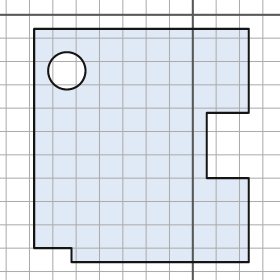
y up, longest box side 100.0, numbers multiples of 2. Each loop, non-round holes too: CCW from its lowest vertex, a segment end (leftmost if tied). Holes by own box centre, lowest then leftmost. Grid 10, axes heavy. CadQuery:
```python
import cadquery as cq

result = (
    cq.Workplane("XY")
    .moveTo(-52.0, -106.0)
    .lineTo(24.0, -106.0)
    .lineTo(24.0, -70.0)
    .lineTo(6.0, -70.0)
    .lineTo(6.0, -42.0)
    .lineTo(24.0, -42.0)
    .lineTo(24.0, -6.0)
    .lineTo(-68.0, -6.0)
    .lineTo(-68.0, -100.0)
    .lineTo(-52.0, -100.0)
    .close()
    .moveTo(-54.0, -24.0)
    .circle(8.0)
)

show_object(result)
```